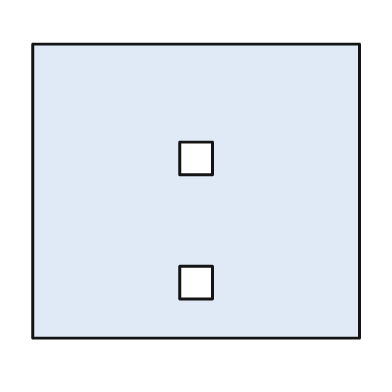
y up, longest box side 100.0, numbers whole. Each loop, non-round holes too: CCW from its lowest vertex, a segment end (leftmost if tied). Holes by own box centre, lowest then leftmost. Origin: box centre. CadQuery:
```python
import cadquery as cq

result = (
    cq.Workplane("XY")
    .moveTo(-50.0, -45.0)
    .lineTo(50.0, -45.0)
    .lineTo(50.0, 45.0)
    .lineTo(-50.0, 45.0)
    .close()
    .moveTo(-5.0, -33.0)
    .lineTo(5.0, -33.0)
    .lineTo(5.0, -23.0)
    .lineTo(-5.0, -23.0)
    .close()
    .moveTo(-5.0, 5.0)
    .lineTo(5.0, 5.0)
    .lineTo(5.0, 15.0)
    .lineTo(-5.0, 15.0)
    .close()
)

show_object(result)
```